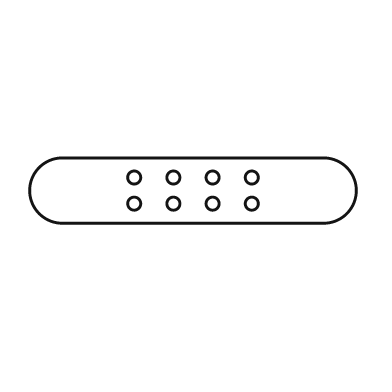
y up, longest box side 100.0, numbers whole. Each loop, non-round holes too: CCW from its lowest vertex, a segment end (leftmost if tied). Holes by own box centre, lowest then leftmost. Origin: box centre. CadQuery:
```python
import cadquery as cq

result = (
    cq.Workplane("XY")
    .moveTo(-40.0, -10.0)
    .lineTo(40.0, -10.0)
    .threePointArc((50.0, 0.0), (40.0, 10.0))
    .lineTo(-40.0, 10.0)
    .threePointArc((-50.0, 0.0), (-40.0, -10.0))
    .close()
    .moveTo(-18.0, -4.0)
    .circle(2.0)
    .moveTo(-6.0, -4.0)
    .circle(2.0)
    .moveTo(6.0, -4.0)
    .circle(2.0)
    .moveTo(18.0, -4.0)
    .circle(2.0)
    .moveTo(-18.0, 4.0)
    .circle(2.0)
    .moveTo(-6.0, 4.0)
    .circle(2.0)
    .moveTo(6.0, 4.0)
    .circle(2.0)
    .moveTo(18.0, 4.0)
    .circle(2.0)
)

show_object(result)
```